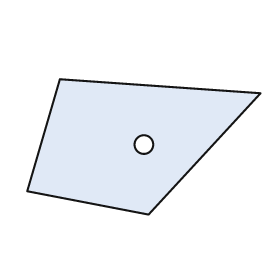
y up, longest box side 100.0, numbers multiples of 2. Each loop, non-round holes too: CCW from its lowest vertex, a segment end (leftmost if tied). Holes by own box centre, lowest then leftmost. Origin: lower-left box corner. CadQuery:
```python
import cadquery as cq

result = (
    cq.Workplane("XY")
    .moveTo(52.0, 0.0)
    .lineTo(100.0, 52.0)
    .lineTo(14.0, 58.0)
    .lineTo(0.0, 10.0)
    .close()
    .moveTo(50.0, 30.0)
    .circle(4.0)
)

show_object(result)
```